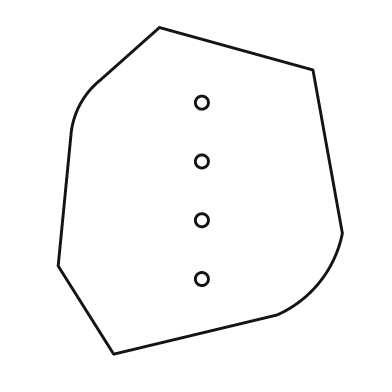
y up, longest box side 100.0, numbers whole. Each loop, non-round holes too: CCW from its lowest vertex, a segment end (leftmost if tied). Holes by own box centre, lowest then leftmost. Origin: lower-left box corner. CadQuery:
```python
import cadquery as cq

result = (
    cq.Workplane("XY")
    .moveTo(17.0, 0.0)
    .lineTo(67.0, 12.0)
    .threePointArc((80.0, 22.0), (87.0, 37.0))
    .lineTo(78.0, 87.0)
    .lineTo(31.0, 100.0)
    .lineTo(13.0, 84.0)
    .threePointArc((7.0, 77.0), (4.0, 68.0))
    .lineTo(0.0, 27.0)
    .close()
    .moveTo(44.0, 23.0)
    .circle(2.0)
    .moveTo(44.0, 41.0)
    .circle(2.0)
    .moveTo(44.0, 59.0)
    .circle(2.0)
    .moveTo(44.0, 77.0)
    .circle(2.0)
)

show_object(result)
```